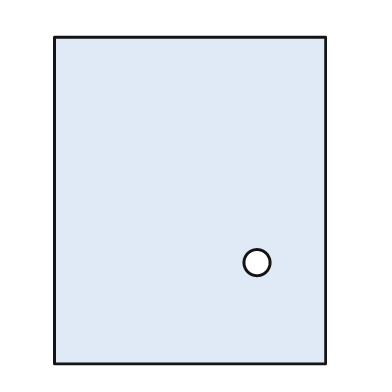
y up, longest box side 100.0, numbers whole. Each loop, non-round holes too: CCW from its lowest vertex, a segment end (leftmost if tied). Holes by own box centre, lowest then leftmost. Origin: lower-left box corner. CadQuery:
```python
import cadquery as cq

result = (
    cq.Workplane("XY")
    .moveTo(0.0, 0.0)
    .lineTo(83.0, 0.0)
    .lineTo(83.0, 100.0)
    .lineTo(0.0, 100.0)
    .close()
    .moveTo(62.0, 31.0)
    .circle(4.0)
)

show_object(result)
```